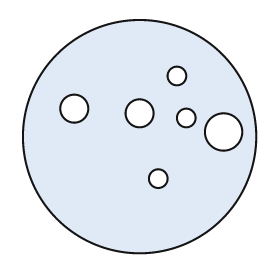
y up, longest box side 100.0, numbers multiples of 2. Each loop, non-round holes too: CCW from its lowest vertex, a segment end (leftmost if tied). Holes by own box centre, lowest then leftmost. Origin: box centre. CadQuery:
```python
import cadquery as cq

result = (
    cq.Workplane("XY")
    .moveTo(0.0, 0.0)
    .circle(50.0)
    .moveTo(8.0, -18.0)
    .circle(4.0)
    .moveTo(36.0, 2.0)
    .circle(8.0)
    .moveTo(20.0, 8.0)
    .circle(4.0)
    .moveTo(0.0, 10.0)
    .circle(6.0)
    .moveTo(-28.0, 12.0)
    .circle(6.0)
    .moveTo(16.0, 26.0)
    .circle(4.0)
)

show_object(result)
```